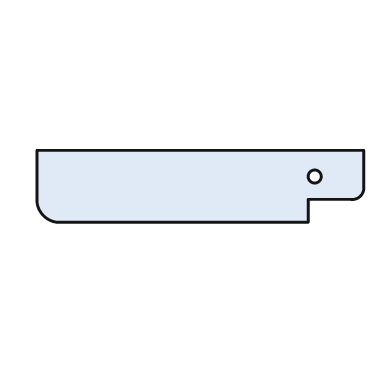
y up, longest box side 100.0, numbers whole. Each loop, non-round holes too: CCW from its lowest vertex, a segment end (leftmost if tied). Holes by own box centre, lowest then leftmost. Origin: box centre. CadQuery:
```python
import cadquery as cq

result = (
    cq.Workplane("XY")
    .moveTo(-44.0, -11.0)
    .lineTo(33.0, -11.0)
    .lineTo(33.0, -4.0)
    .lineTo(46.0, -4.0)
    .threePointArc((49.0, -3.0), (50.0, 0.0))
    .lineTo(50.0, 11.0)
    .lineTo(-50.0, 11.0)
    .lineTo(-50.0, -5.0)
    .threePointArc((-48.0, -9.0), (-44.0, -11.0))
    .close()
    .moveTo(35.0, 3.0)
    .circle(2.0)
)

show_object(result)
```